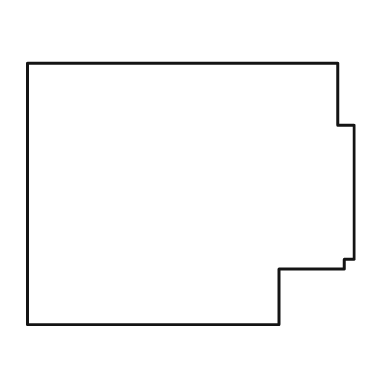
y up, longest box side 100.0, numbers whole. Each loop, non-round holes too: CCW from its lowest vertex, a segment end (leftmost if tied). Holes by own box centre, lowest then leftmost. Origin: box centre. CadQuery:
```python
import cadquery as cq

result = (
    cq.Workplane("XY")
    .moveTo(-50.0, -40.0)
    .lineTo(27.0, -40.0)
    .lineTo(27.0, -23.0)
    .lineTo(47.0, -23.0)
    .lineTo(47.0, -20.0)
    .lineTo(50.0, -20.0)
    .lineTo(50.0, 21.0)
    .lineTo(45.0, 21.0)
    .lineTo(45.0, 40.0)
    .lineTo(-50.0, 40.0)
    .close()
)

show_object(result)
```